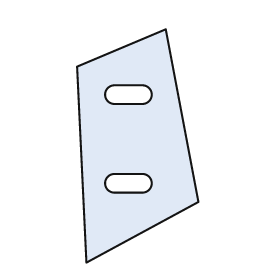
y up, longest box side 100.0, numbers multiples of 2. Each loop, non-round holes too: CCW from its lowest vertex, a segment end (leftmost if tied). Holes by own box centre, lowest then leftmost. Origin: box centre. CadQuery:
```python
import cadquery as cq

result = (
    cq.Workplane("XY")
    .moveTo(-22.0, -50.0)
    .lineTo(26.0, -24.0)
    .lineTo(12.0, 50.0)
    .lineTo(-26.0, 34.0)
    .close()
    .moveTo(-10.0, -20.0)
    .lineTo(2.0, -20.0)
    .threePointArc((6.0, -16.0), (2.0, -12.0))
    .lineTo(-10.0, -12.0)
    .threePointArc((-14.0, -16.0), (-10.0, -20.0))
    .close()
    .moveTo(-10.0, 18.0)
    .lineTo(2.0, 18.0)
    .threePointArc((6.0, 22.0), (2.0, 26.0))
    .lineTo(-10.0, 26.0)
    .threePointArc((-14.0, 22.0), (-10.0, 18.0))
    .close()
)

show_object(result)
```